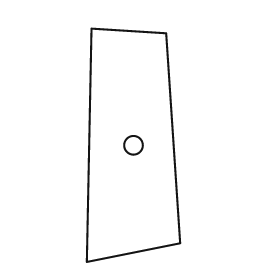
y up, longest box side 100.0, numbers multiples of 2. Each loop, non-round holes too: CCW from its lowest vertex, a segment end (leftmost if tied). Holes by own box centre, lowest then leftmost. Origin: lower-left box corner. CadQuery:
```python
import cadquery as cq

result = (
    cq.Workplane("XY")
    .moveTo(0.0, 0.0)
    .lineTo(40.0, 8.0)
    .lineTo(34.0, 98.0)
    .lineTo(2.0, 100.0)
    .close()
    .moveTo(20.0, 50.0)
    .circle(4.0)
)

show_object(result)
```